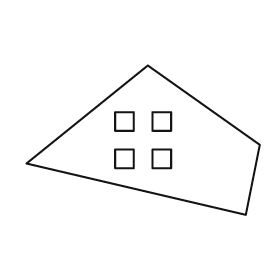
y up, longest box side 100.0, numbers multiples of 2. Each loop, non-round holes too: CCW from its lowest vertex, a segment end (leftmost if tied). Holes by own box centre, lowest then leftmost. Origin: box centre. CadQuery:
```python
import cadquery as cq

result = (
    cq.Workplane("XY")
    .moveTo(44.0, -32.0)
    .lineTo(50.0, -2.0)
    .lineTo(2.0, 32.0)
    .lineTo(-50.0, -10.0)
    .close()
    .moveTo(-12.0, -12.0)
    .lineTo(-4.0, -12.0)
    .lineTo(-4.0, -4.0)
    .lineTo(-12.0, -4.0)
    .close()
    .moveTo(4.0, -12.0)
    .lineTo(12.0, -12.0)
    .lineTo(12.0, -4.0)
    .lineTo(4.0, -4.0)
    .close()
    .moveTo(-12.0, 4.0)
    .lineTo(-4.0, 4.0)
    .lineTo(-4.0, 12.0)
    .lineTo(-12.0, 12.0)
    .close()
    .moveTo(4.0, 4.0)
    .lineTo(12.0, 4.0)
    .lineTo(12.0, 12.0)
    .lineTo(4.0, 12.0)
    .close()
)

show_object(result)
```